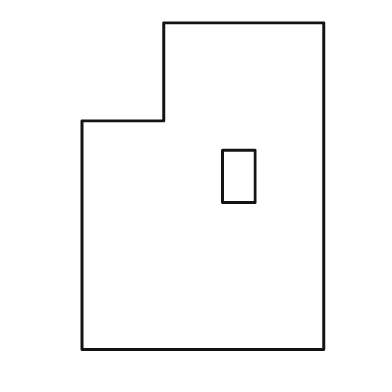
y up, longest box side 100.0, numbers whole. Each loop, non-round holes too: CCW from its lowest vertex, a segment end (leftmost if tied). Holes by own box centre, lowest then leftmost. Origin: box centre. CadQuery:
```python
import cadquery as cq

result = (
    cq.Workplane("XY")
    .moveTo(-37.0, -50.0)
    .lineTo(37.0, -50.0)
    .lineTo(37.0, 50.0)
    .lineTo(-12.0, 50.0)
    .lineTo(-12.0, 20.0)
    .lineTo(-37.0, 20.0)
    .close()
    .moveTo(6.0, -5.0)
    .lineTo(16.0, -5.0)
    .lineTo(16.0, 11.0)
    .lineTo(6.0, 11.0)
    .close()
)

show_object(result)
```